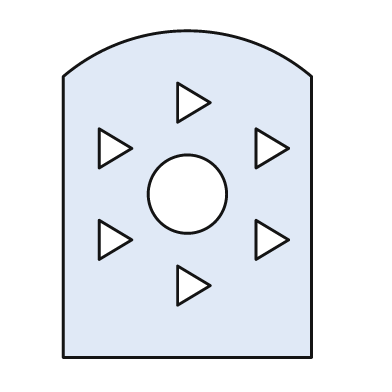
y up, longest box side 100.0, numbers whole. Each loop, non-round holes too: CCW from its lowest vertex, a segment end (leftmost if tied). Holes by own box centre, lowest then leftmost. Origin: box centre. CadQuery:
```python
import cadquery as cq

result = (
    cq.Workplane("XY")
    .moveTo(-38.0, -50.0)
    .lineTo(38.0, -50.0)
    .lineTo(38.0, 36.0)
    .threePointArc((0.0, 50.0), (-38.0, 36.0))
    .close()
    .moveTo(-3.0, -34.0)
    .lineTo(7.0, -28.0)
    .lineTo(-3.0, -22.0)
    .close()
    .moveTo(-27.0, -20.0)
    .lineTo(-17.0, -14.0)
    .lineTo(-27.0, -8.0)
    .close()
    .moveTo(21.0, -20.0)
    .lineTo(31.0, -14.0)
    .lineTo(21.0, -8.0)
    .close()
    .moveTo(0.0, 0.0)
    .circle(12.0)
    .moveTo(-27.0, 8.0)
    .lineTo(-17.0, 14.0)
    .lineTo(-27.0, 20.0)
    .close()
    .moveTo(21.0, 8.0)
    .lineTo(31.0, 14.0)
    .lineTo(21.0, 20.0)
    .close()
    .moveTo(-3.0, 22.0)
    .lineTo(7.0, 28.0)
    .lineTo(-3.0, 34.0)
    .close()
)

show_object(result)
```